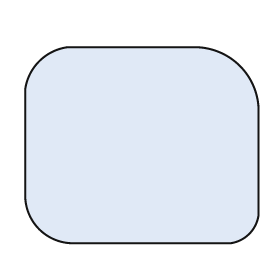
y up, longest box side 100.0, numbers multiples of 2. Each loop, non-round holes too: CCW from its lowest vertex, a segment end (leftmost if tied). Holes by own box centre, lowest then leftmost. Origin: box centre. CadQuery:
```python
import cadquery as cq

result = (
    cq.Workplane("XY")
    .moveTo(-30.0, -42.0)
    .lineTo(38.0, -42.0)
    .threePointArc((46.0, -38.0), (50.0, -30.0))
    .lineTo(50.0, 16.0)
    .threePointArc((42.0, 34.0), (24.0, 42.0))
    .lineTo(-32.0, 42.0)
    .threePointArc((-44.0, 36.0), (-50.0, 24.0))
    .lineTo(-50.0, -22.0)
    .threePointArc((-44.0, -36.0), (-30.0, -42.0))
    .close()
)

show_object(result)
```